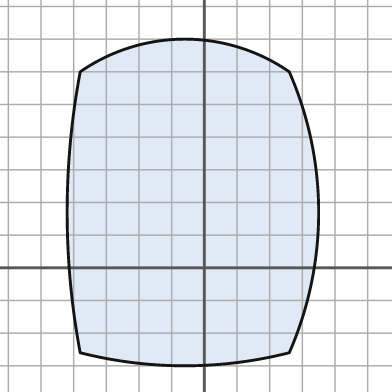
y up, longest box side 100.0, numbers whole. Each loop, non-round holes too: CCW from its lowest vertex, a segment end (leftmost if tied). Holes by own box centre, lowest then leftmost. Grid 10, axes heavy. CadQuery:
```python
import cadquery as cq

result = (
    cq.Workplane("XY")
    .moveTo(-38.0, -26.0)
    .threePointArc((-6.0, -30.0), (26.0, -26.0))
    .threePointArc((35.0, 17.0), (26.0, 60.0))
    .threePointArc((-6.0, 70.0), (-38.0, 60.0))
    .threePointArc((-42.0, 17.0), (-38.0, -26.0))
    .close()
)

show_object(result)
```